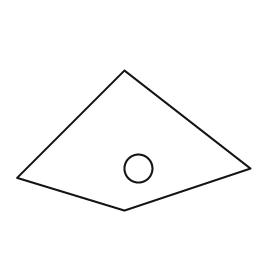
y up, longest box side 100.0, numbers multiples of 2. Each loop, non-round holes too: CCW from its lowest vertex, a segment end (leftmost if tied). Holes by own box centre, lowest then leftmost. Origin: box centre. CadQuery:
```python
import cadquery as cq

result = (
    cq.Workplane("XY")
    .moveTo(-4.0, -30.0)
    .lineTo(50.0, -12.0)
    .lineTo(-4.0, 30.0)
    .lineTo(-50.0, -16.0)
    .close()
    .moveTo(2.0, -12.0)
    .circle(6.0)
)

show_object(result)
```